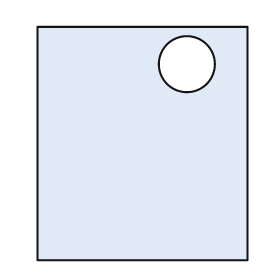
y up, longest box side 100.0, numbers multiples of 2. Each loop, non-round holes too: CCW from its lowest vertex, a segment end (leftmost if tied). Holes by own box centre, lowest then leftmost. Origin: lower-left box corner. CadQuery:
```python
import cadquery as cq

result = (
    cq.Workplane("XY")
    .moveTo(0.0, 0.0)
    .lineTo(90.0, 0.0)
    .lineTo(90.0, 100.0)
    .lineTo(0.0, 100.0)
    .close()
    .moveTo(64.0, 84.0)
    .circle(12.0)
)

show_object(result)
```